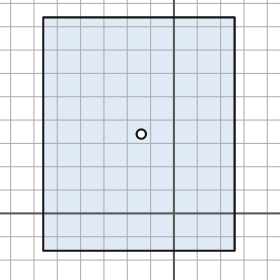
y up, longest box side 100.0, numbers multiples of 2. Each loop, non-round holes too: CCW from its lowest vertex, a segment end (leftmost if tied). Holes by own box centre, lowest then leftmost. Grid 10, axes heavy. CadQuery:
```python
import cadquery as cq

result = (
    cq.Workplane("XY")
    .moveTo(-56.0, -16.0)
    .lineTo(26.0, -16.0)
    .lineTo(26.0, 84.0)
    .lineTo(-56.0, 84.0)
    .close()
    .moveTo(-14.0, 34.0)
    .circle(2.0)
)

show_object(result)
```